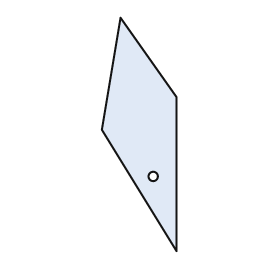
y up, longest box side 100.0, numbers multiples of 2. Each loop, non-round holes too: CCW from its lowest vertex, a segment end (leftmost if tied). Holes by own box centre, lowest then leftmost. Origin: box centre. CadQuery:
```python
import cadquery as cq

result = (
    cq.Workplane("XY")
    .moveTo(16.0, -50.0)
    .lineTo(16.0, 16.0)
    .lineTo(-8.0, 50.0)
    .lineTo(-16.0, 2.0)
    .close()
    .moveTo(6.0, -18.0)
    .circle(2.0)
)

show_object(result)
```